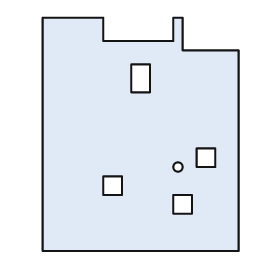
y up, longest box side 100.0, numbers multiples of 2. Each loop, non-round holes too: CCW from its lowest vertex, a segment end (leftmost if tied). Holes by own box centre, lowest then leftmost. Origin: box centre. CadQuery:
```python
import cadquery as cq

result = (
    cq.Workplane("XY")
    .moveTo(-42.0, -50.0)
    .lineTo(42.0, -50.0)
    .lineTo(42.0, 36.0)
    .lineTo(18.0, 36.0)
    .lineTo(18.0, 50.0)
    .lineTo(14.0, 50.0)
    .lineTo(14.0, 40.0)
    .lineTo(-16.0, 40.0)
    .lineTo(-16.0, 50.0)
    .lineTo(-42.0, 50.0)
    .close()
    .moveTo(14.0, -34.0)
    .lineTo(22.0, -34.0)
    .lineTo(22.0, -26.0)
    .lineTo(14.0, -26.0)
    .close()
    .moveTo(-16.0, -26.0)
    .lineTo(-8.0, -26.0)
    .lineTo(-8.0, -18.0)
    .lineTo(-16.0, -18.0)
    .close()
    .moveTo(16.0, -14.0)
    .circle(2.0)
    .moveTo(24.0, -14.0)
    .lineTo(32.0, -14.0)
    .lineTo(32.0, -6.0)
    .lineTo(24.0, -6.0)
    .close()
    .moveTo(-4.0, 18.0)
    .lineTo(4.0, 18.0)
    .lineTo(4.0, 30.0)
    .lineTo(-4.0, 30.0)
    .close()
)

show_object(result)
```